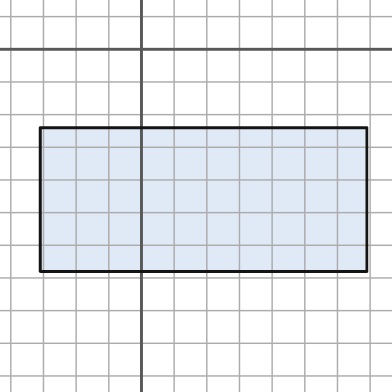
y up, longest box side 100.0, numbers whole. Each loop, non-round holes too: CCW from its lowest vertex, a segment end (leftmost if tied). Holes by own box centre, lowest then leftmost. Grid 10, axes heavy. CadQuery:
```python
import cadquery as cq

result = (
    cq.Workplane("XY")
    .moveTo(-31.0, -68.0)
    .lineTo(69.0, -68.0)
    .lineTo(69.0, -24.0)
    .lineTo(-31.0, -24.0)
    .close()
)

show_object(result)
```